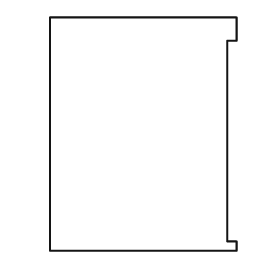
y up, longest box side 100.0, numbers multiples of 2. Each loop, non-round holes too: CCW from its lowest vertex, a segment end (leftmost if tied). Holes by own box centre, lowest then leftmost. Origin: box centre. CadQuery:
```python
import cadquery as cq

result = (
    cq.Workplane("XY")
    .moveTo(-40.0, -50.0)
    .lineTo(40.0, -50.0)
    .lineTo(40.0, -46.0)
    .lineTo(36.0, -46.0)
    .lineTo(36.0, 40.0)
    .lineTo(40.0, 40.0)
    .lineTo(40.0, 50.0)
    .lineTo(-40.0, 50.0)
    .close()
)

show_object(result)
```